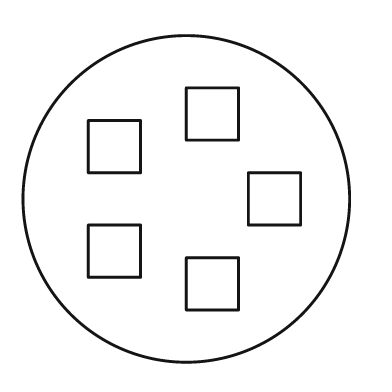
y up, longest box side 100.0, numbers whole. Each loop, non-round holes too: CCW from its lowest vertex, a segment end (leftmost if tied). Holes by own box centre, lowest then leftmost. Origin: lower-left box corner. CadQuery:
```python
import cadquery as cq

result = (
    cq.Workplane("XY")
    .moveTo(50.0, 50.0)
    .circle(50.0)
    .moveTo(50.0, 16.0)
    .lineTo(66.0, 16.0)
    .lineTo(66.0, 32.0)
    .lineTo(50.0, 32.0)
    .close()
    .moveTo(20.0, 26.0)
    .lineTo(36.0, 26.0)
    .lineTo(36.0, 42.0)
    .lineTo(20.0, 42.0)
    .close()
    .moveTo(69.0, 42.0)
    .lineTo(85.0, 42.0)
    .lineTo(85.0, 58.0)
    .lineTo(69.0, 58.0)
    .close()
    .moveTo(20.0, 58.0)
    .lineTo(36.0, 58.0)
    .lineTo(36.0, 74.0)
    .lineTo(20.0, 74.0)
    .close()
    .moveTo(50.0, 68.0)
    .lineTo(66.0, 68.0)
    .lineTo(66.0, 84.0)
    .lineTo(50.0, 84.0)
    .close()
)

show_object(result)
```